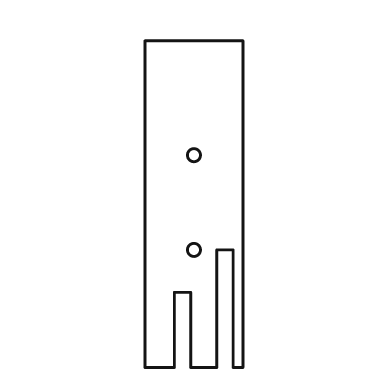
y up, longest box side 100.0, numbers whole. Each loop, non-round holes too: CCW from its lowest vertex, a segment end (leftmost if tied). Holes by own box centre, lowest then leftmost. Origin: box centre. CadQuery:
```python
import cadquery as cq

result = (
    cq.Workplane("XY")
    .moveTo(-15.0, -50.0)
    .lineTo(-6.0, -50.0)
    .lineTo(-6.0, -27.0)
    .lineTo(-1.0, -27.0)
    .lineTo(-1.0, -50.0)
    .lineTo(7.0, -50.0)
    .lineTo(7.0, -14.0)
    .lineTo(12.0, -14.0)
    .lineTo(12.0, -50.0)
    .lineTo(15.0, -50.0)
    .lineTo(15.0, 50.0)
    .lineTo(-15.0, 50.0)
    .close()
    .moveTo(0.0, -14.0)
    .circle(2.0)
    .moveTo(0.0, 15.0)
    .circle(2.0)
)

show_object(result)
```